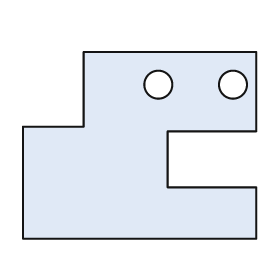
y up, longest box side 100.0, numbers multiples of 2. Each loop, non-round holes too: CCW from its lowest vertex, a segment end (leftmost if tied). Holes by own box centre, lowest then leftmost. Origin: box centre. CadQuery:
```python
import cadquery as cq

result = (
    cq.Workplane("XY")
    .moveTo(-50.0, -40.0)
    .lineTo(50.0, -40.0)
    .lineTo(50.0, -18.0)
    .lineTo(12.0, -18.0)
    .lineTo(12.0, 6.0)
    .lineTo(50.0, 6.0)
    .lineTo(50.0, 40.0)
    .lineTo(-24.0, 40.0)
    .lineTo(-24.0, 8.0)
    .lineTo(-50.0, 8.0)
    .close()
    .moveTo(8.0, 26.0)
    .circle(6.0)
    .moveTo(40.0, 26.0)
    .circle(6.0)
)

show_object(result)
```